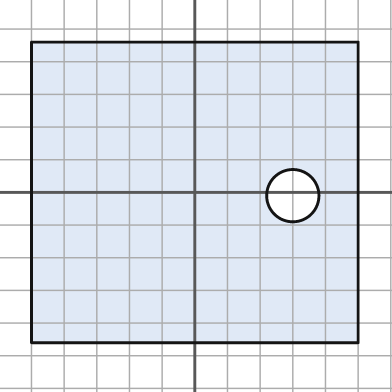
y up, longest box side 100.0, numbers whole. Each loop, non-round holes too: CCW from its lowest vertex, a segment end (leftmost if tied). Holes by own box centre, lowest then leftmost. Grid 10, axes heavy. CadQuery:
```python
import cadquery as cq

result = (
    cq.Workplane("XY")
    .moveTo(-50.0, -46.0)
    .lineTo(50.0, -46.0)
    .lineTo(50.0, 46.0)
    .lineTo(-50.0, 46.0)
    .close()
    .moveTo(30.0, -1.0)
    .circle(8.0)
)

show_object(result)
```